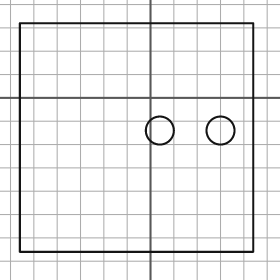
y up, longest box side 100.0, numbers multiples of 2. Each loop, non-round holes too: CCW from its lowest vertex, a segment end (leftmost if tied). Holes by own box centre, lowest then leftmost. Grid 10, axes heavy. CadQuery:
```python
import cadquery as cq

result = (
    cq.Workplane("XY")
    .moveTo(-56.0, -66.0)
    .lineTo(44.0, -66.0)
    .lineTo(44.0, 32.0)
    .lineTo(-56.0, 32.0)
    .close()
    .moveTo(4.0, -14.0)
    .circle(6.0)
    .moveTo(30.0, -14.0)
    .circle(6.0)
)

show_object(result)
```